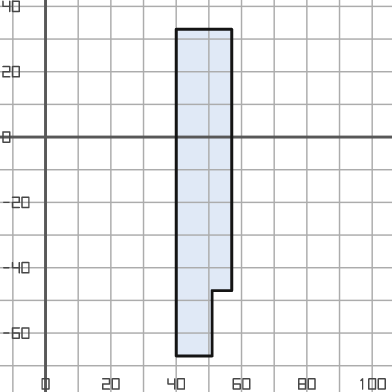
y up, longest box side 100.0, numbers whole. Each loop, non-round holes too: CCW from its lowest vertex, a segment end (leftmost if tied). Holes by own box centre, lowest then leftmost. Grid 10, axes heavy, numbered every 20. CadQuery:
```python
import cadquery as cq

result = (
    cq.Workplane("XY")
    .moveTo(40.0, -67.0)
    .lineTo(51.0, -67.0)
    .lineTo(51.0, -47.0)
    .lineTo(57.0, -47.0)
    .lineTo(57.0, 33.0)
    .lineTo(40.0, 33.0)
    .close()
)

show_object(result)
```